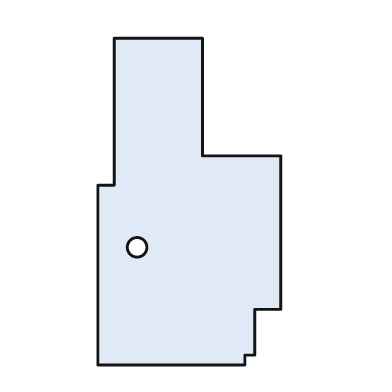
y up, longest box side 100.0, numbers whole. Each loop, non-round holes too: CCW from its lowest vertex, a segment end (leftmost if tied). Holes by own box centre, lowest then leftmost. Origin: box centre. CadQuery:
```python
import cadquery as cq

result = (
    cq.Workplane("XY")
    .moveTo(-28.0, -50.0)
    .lineTo(17.0, -50.0)
    .lineTo(17.0, -47.0)
    .lineTo(20.0, -47.0)
    .lineTo(20.0, -33.0)
    .lineTo(28.0, -33.0)
    .lineTo(28.0, 14.0)
    .lineTo(4.0, 14.0)
    .lineTo(4.0, 50.0)
    .lineTo(-23.0, 50.0)
    .lineTo(-23.0, 5.0)
    .lineTo(-28.0, 5.0)
    .close()
    .moveTo(-16.0, -14.0)
    .circle(3.0)
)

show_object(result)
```